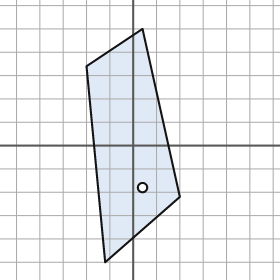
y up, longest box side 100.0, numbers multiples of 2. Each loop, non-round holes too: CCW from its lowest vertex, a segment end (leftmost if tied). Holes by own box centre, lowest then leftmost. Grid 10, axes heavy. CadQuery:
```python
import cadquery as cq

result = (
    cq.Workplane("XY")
    .moveTo(-12.0, -50.0)
    .lineTo(20.0, -22.0)
    .lineTo(4.0, 50.0)
    .lineTo(-20.0, 34.0)
    .close()
    .moveTo(4.0, -18.0)
    .circle(2.0)
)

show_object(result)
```